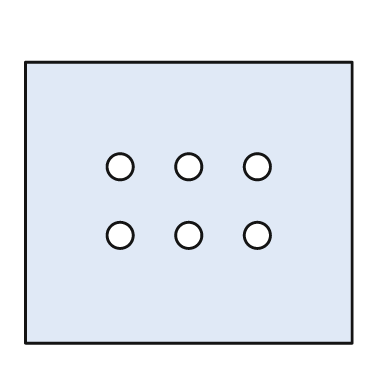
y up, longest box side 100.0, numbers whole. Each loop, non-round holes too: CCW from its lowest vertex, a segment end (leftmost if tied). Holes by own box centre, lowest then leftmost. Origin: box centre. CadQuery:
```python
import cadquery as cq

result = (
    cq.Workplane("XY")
    .moveTo(-50.0, -43.0)
    .lineTo(50.0, -43.0)
    .lineTo(50.0, 43.0)
    .lineTo(-50.0, 43.0)
    .close()
    .moveTo(-21.0, -10.0)
    .circle(4.0)
    .moveTo(0.0, -10.0)
    .circle(4.0)
    .moveTo(21.0, -10.0)
    .circle(4.0)
    .moveTo(-21.0, 11.0)
    .circle(4.0)
    .moveTo(0.0, 11.0)
    .circle(4.0)
    .moveTo(21.0, 11.0)
    .circle(4.0)
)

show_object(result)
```